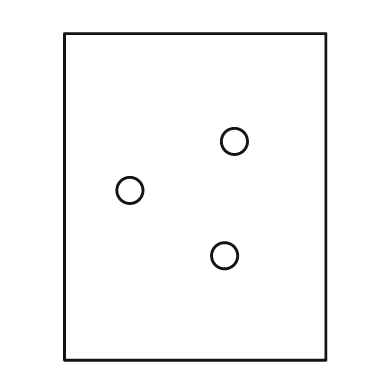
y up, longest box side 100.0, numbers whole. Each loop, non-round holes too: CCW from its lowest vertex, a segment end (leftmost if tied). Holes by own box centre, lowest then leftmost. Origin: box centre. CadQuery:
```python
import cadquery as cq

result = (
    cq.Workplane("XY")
    .moveTo(-40.0, -50.0)
    .lineTo(40.0, -50.0)
    .lineTo(40.0, 50.0)
    .lineTo(-40.0, 50.0)
    .close()
    .moveTo(9.0, -18.0)
    .circle(4.0)
    .moveTo(-20.0, 2.0)
    .circle(4.0)
    .moveTo(12.0, 17.0)
    .circle(4.0)
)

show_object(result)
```